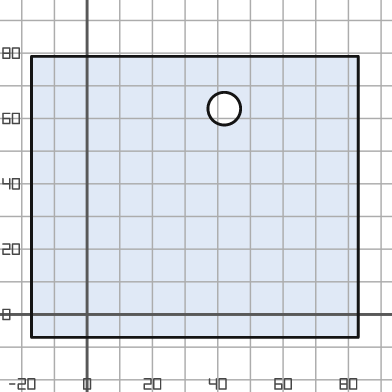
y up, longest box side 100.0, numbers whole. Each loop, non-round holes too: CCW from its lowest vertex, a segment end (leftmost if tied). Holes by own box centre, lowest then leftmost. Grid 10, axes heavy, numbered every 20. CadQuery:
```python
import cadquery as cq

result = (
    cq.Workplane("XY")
    .moveTo(-17.0, -7.0)
    .lineTo(83.0, -7.0)
    .lineTo(83.0, 79.0)
    .lineTo(-17.0, 79.0)
    .close()
    .moveTo(42.0, 63.0)
    .circle(5.0)
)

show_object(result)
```